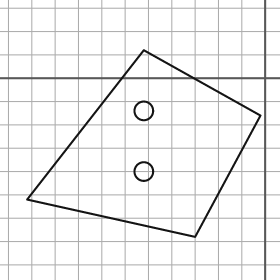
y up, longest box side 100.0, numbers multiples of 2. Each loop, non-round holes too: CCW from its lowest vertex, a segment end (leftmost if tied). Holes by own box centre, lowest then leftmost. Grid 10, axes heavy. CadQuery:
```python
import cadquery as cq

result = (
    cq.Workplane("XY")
    .moveTo(-30.0, -68.0)
    .lineTo(-2.0, -16.0)
    .lineTo(-52.0, 12.0)
    .lineTo(-102.0, -52.0)
    .close()
    .moveTo(-52.0, -40.0)
    .circle(4.0)
    .moveTo(-52.0, -14.0)
    .circle(4.0)
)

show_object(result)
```